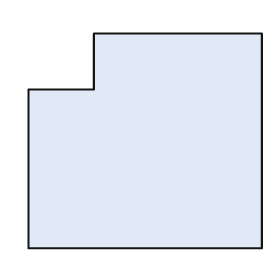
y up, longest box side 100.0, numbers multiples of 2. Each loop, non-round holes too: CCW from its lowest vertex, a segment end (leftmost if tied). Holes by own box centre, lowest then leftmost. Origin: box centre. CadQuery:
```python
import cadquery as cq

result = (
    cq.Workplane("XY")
    .moveTo(-50.0, -46.0)
    .lineTo(50.0, -46.0)
    .lineTo(50.0, 46.0)
    .lineTo(-22.0, 46.0)
    .lineTo(-22.0, 22.0)
    .lineTo(-50.0, 22.0)
    .close()
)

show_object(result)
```